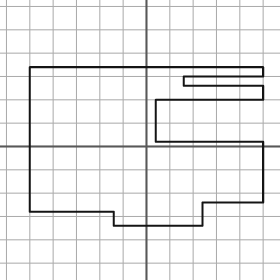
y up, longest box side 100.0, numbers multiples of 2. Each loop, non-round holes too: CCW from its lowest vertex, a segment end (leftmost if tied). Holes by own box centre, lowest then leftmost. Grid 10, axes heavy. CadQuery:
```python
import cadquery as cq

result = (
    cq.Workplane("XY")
    .moveTo(-14.0, -34.0)
    .lineTo(24.0, -34.0)
    .lineTo(24.0, -24.0)
    .lineTo(50.0, -24.0)
    .lineTo(50.0, 2.0)
    .lineTo(4.0, 2.0)
    .lineTo(4.0, 20.0)
    .lineTo(50.0, 20.0)
    .lineTo(50.0, 26.0)
    .lineTo(16.0, 26.0)
    .lineTo(16.0, 30.0)
    .lineTo(50.0, 30.0)
    .lineTo(50.0, 34.0)
    .lineTo(-50.0, 34.0)
    .lineTo(-50.0, -28.0)
    .lineTo(-14.0, -28.0)
    .close()
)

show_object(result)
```